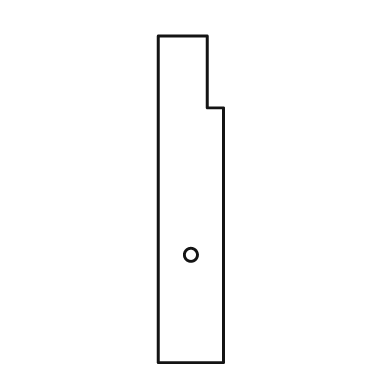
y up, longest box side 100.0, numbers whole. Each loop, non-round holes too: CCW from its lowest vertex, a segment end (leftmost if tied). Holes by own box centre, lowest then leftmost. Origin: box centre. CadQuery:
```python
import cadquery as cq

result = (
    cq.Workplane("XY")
    .moveTo(-10.0, -50.0)
    .lineTo(10.0, -50.0)
    .lineTo(10.0, 28.0)
    .lineTo(5.0, 28.0)
    .lineTo(5.0, 50.0)
    .lineTo(-10.0, 50.0)
    .close()
    .moveTo(0.0, -17.0)
    .circle(2.0)
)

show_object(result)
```